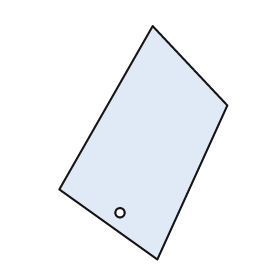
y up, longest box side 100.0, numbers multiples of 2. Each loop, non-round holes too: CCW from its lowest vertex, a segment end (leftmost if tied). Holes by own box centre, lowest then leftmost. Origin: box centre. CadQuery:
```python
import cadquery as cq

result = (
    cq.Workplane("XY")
    .moveTo(6.0, -50.0)
    .lineTo(36.0, 16.0)
    .lineTo(4.0, 50.0)
    .lineTo(-36.0, -20.0)
    .close()
    .moveTo(-10.0, -30.0)
    .circle(2.0)
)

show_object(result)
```